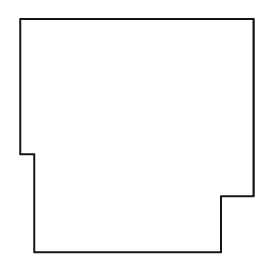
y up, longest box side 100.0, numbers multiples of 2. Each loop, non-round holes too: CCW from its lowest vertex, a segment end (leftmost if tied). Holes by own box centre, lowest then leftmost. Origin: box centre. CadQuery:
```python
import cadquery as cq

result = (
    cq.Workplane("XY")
    .moveTo(-44.0, -50.0)
    .lineTo(36.0, -50.0)
    .lineTo(36.0, -26.0)
    .lineTo(50.0, -26.0)
    .lineTo(50.0, 50.0)
    .lineTo(-50.0, 50.0)
    .lineTo(-50.0, -8.0)
    .lineTo(-44.0, -8.0)
    .close()
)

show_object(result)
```